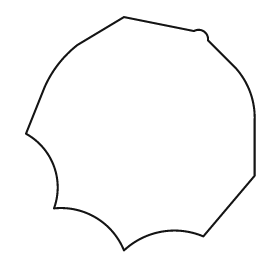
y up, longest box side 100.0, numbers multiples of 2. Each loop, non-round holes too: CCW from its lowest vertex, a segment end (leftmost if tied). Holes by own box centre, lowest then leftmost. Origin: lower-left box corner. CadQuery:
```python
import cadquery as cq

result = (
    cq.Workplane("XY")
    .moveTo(42.0, 0.0)
    .threePointArc((58.0, 8.0), (76.0, 6.0))
    .lineTo(98.0, 32.0)
    .lineTo(98.0, 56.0)
    .threePointArc((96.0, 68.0), (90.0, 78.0))
    .lineTo(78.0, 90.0)
    .threePointArc((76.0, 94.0), (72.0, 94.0))
    .lineTo(42.0, 100.0)
    .lineTo(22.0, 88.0)
    .threePointArc((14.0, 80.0), (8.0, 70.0))
    .lineTo(0.0, 50.0)
    .threePointArc((12.0, 36.0), (12.0, 18.0))
    .threePointArc((30.0, 14.0), (42.0, 0.0))
    .close()
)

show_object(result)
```